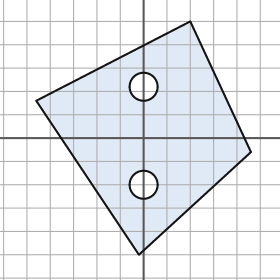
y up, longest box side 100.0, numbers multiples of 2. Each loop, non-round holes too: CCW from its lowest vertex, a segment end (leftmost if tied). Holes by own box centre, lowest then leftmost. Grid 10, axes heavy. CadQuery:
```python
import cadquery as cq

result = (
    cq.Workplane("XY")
    .moveTo(-2.0, -50.0)
    .lineTo(46.0, -6.0)
    .lineTo(20.0, 50.0)
    .lineTo(-46.0, 16.0)
    .close()
    .moveTo(0.0, -20.0)
    .circle(6.0)
    .moveTo(0.0, 22.0)
    .circle(6.0)
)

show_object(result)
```